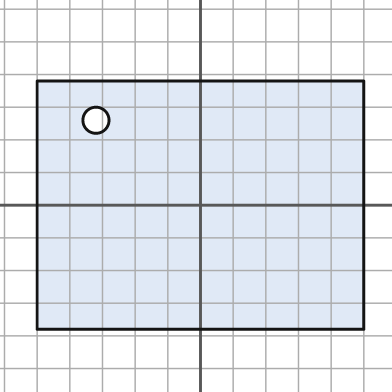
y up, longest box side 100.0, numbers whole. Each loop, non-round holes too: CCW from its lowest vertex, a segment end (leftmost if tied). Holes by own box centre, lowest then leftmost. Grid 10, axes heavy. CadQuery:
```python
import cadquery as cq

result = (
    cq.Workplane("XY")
    .moveTo(-50.0, -38.0)
    .lineTo(50.0, -38.0)
    .lineTo(50.0, 38.0)
    .lineTo(-50.0, 38.0)
    .close()
    .moveTo(-32.0, 26.0)
    .circle(4.0)
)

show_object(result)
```